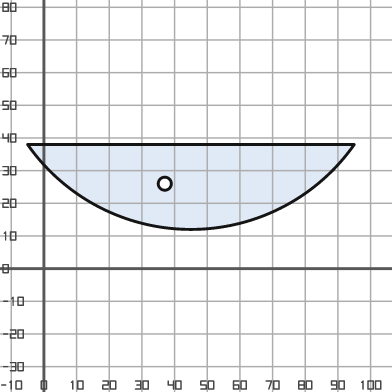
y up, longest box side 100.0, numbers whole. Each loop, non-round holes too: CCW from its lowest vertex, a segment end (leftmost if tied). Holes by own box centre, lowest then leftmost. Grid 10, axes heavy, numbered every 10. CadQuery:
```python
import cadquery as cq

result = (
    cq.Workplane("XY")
    .moveTo(-5.0, 38.0)
    .threePointArc((45.0, 12.0), (95.0, 38.0))
    .close()
    .moveTo(37.0, 26.0)
    .circle(2.0)
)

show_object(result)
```